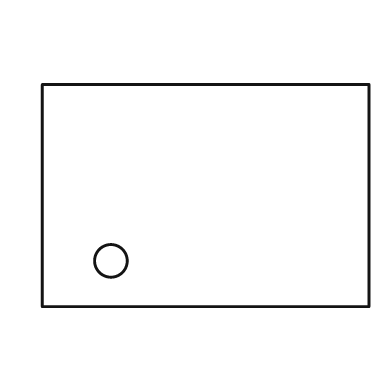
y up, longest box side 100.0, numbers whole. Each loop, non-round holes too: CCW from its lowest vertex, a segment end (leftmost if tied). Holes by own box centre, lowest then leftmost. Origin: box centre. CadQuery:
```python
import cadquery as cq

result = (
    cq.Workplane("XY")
    .moveTo(-50.0, -34.0)
    .lineTo(50.0, -34.0)
    .lineTo(50.0, 34.0)
    .lineTo(-50.0, 34.0)
    .close()
    .moveTo(-29.0, -20.0)
    .circle(5.0)
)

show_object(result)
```